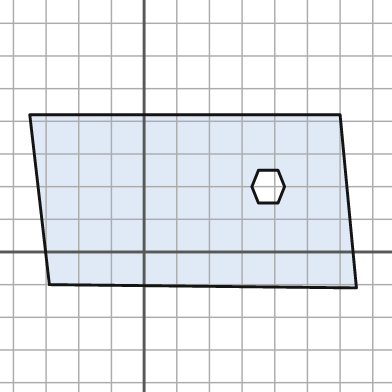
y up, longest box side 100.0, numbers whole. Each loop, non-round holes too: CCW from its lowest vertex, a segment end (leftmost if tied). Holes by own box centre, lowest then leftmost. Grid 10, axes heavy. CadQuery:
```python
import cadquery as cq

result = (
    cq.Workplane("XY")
    .moveTo(65.0, -11.0)
    .lineTo(60.0, 42.0)
    .lineTo(-35.0, 42.0)
    .lineTo(-29.0, -10.0)
    .close()
    .moveTo(35.0, 15.0)
    .lineTo(41.0, 15.0)
    .lineTo(43.0, 20.0)
    .lineTo(41.0, 25.0)
    .lineTo(35.0, 25.0)
    .lineTo(33.0, 20.0)
    .close()
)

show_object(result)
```